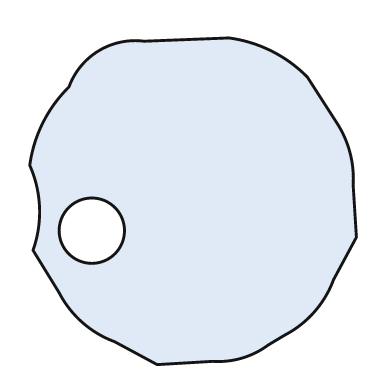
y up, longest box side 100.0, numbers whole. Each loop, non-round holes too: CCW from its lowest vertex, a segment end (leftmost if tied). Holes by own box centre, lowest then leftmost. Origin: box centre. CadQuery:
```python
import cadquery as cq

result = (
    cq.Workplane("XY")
    .moveTo(-11.0, -50.0)
    .lineTo(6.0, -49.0)
    .threePointArc((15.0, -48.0), (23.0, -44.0))
    .lineTo(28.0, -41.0)
    .threePointArc((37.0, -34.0), (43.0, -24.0))
    .lineTo(50.0, -11.0)
    .lineTo(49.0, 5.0)
    .threePointArc((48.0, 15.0), (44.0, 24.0))
    .lineTo(35.0, 38.0)
    .threePointArc((24.0, 46.0), (11.0, 50.0))
    .lineTo(-15.0, 49.0)
    .threePointArc((-29.0, 46.0), (-38.0, 35.0))
    .threePointArc((-46.0, 24.0), (-50.0, 11.0))
    .threePointArc((-47.0, -2.0), (-49.0, -15.0))
    .lineTo(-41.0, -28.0)
    .threePointArc((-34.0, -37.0), (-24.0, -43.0))
    .close()
    .moveTo(-31.0, -9.0)
    .circle(10.0)
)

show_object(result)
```